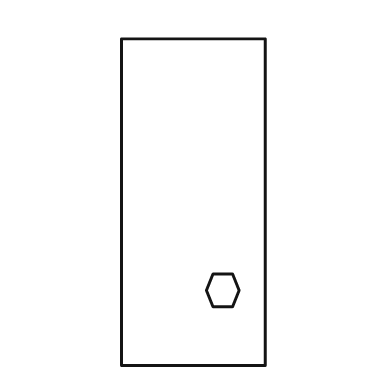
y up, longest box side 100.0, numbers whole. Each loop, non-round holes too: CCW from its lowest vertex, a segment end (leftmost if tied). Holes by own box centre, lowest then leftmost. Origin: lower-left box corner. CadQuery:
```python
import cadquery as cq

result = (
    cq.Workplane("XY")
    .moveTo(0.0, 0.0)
    .lineTo(44.0, 0.0)
    .lineTo(44.0, 100.0)
    .lineTo(0.0, 100.0)
    .close()
    .moveTo(28.0, 18.0)
    .lineTo(34.0, 18.0)
    .lineTo(36.0, 23.0)
    .lineTo(34.0, 28.0)
    .lineTo(28.0, 28.0)
    .lineTo(26.0, 23.0)
    .close()
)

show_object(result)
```